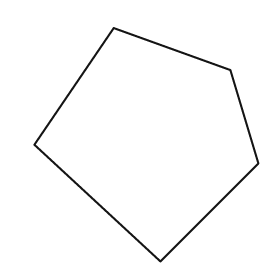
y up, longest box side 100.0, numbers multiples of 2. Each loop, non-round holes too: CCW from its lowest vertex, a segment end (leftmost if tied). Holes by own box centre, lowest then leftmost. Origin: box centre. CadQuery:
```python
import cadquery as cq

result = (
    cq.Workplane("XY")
    .moveTo(6.0, -50.0)
    .lineTo(48.0, -8.0)
    .lineTo(36.0, 32.0)
    .lineTo(-14.0, 50.0)
    .lineTo(-48.0, 0.0)
    .close()
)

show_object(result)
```